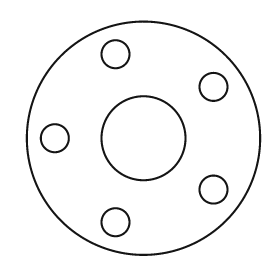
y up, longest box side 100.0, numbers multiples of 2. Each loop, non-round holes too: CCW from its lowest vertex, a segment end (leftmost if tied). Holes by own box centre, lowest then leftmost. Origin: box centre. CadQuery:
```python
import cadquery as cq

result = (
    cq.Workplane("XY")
    .moveTo(0.0, 0.0)
    .circle(50.0)
    .moveTo(-12.0, -36.0)
    .circle(6.0)
    .moveTo(30.0, -22.0)
    .circle(6.0)
    .moveTo(-38.0, 0.0)
    .circle(6.0)
    .moveTo(0.0, 0.0)
    .circle(18.0)
    .moveTo(30.0, 22.0)
    .circle(6.0)
    .moveTo(-12.0, 36.0)
    .circle(6.0)
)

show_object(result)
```